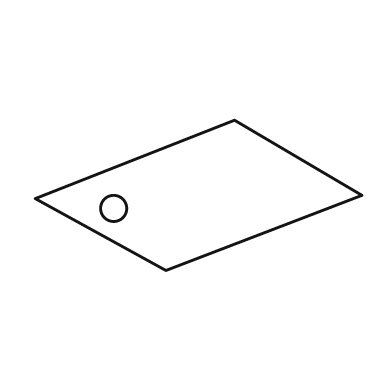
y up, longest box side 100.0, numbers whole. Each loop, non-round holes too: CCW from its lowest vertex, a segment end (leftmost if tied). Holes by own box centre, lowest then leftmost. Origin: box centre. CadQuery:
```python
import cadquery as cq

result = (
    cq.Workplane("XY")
    .moveTo(-10.0, -23.0)
    .lineTo(50.0, 0.0)
    .lineTo(11.0, 23.0)
    .lineTo(-50.0, -1.0)
    .close()
    .moveTo(-26.0, -4.0)
    .circle(4.0)
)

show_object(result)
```